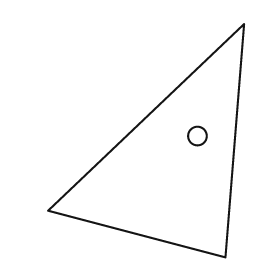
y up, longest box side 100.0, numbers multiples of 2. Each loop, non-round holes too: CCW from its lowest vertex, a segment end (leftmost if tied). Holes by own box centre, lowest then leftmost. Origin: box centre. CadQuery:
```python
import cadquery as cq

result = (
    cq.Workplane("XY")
    .moveTo(34.0, -50.0)
    .lineTo(42.0, 50.0)
    .lineTo(-42.0, -30.0)
    .close()
    .moveTo(22.0, 2.0)
    .circle(4.0)
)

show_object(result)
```